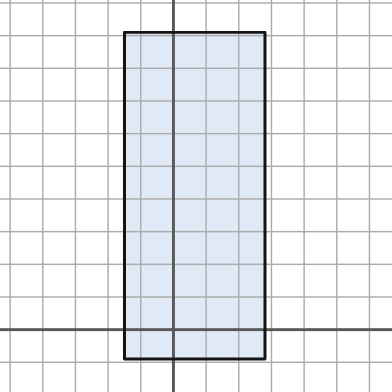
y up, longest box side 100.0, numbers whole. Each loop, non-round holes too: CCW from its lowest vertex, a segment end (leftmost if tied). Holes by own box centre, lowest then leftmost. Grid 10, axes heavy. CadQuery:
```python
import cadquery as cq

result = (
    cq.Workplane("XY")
    .moveTo(-15.0, -9.0)
    .lineTo(28.0, -9.0)
    .lineTo(28.0, 91.0)
    .lineTo(-15.0, 91.0)
    .close()
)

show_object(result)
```